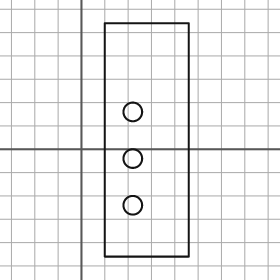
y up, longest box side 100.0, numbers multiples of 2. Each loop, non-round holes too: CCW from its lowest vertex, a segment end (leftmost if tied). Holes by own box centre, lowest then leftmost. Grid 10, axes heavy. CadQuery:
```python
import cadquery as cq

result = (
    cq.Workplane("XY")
    .moveTo(10.0, -46.0)
    .lineTo(46.0, -46.0)
    .lineTo(46.0, 54.0)
    .lineTo(10.0, 54.0)
    .close()
    .moveTo(22.0, -24.0)
    .circle(4.0)
    .moveTo(22.0, -4.0)
    .circle(4.0)
    .moveTo(22.0, 16.0)
    .circle(4.0)
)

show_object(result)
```